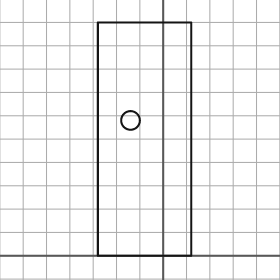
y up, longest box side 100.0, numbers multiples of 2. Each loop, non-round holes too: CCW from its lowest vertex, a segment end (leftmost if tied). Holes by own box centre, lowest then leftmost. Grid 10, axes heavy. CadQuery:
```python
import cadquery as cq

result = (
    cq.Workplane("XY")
    .moveTo(-28.0, 0.0)
    .lineTo(12.0, 0.0)
    .lineTo(12.0, 100.0)
    .lineTo(-28.0, 100.0)
    .close()
    .moveTo(-14.0, 58.0)
    .circle(4.0)
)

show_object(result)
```